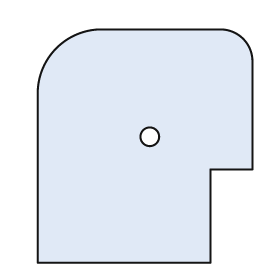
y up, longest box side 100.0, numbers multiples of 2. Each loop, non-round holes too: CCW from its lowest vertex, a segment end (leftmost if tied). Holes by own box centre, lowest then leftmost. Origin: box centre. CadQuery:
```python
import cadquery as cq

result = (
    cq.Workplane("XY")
    .moveTo(-46.0, -50.0)
    .lineTo(28.0, -50.0)
    .lineTo(28.0, -10.0)
    .lineTo(46.0, -10.0)
    .lineTo(46.0, 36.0)
    .threePointArc((42.0, 46.0), (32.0, 50.0))
    .lineTo(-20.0, 50.0)
    .threePointArc((-38.0, 42.0), (-46.0, 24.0))
    .close()
    .moveTo(2.0, 4.0)
    .circle(4.0)
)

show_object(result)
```